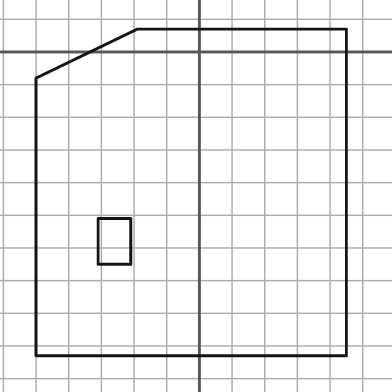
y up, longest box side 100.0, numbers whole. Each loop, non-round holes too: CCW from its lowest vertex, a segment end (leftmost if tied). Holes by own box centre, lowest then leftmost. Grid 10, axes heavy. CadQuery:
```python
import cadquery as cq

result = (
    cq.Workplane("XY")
    .moveTo(-50.0, -93.0)
    .lineTo(45.0, -93.0)
    .lineTo(45.0, 7.0)
    .lineTo(-19.0, 7.0)
    .lineTo(-50.0, -8.0)
    .close()
    .moveTo(-31.0, -65.0)
    .lineTo(-21.0, -65.0)
    .lineTo(-21.0, -51.0)
    .lineTo(-31.0, -51.0)
    .close()
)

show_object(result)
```